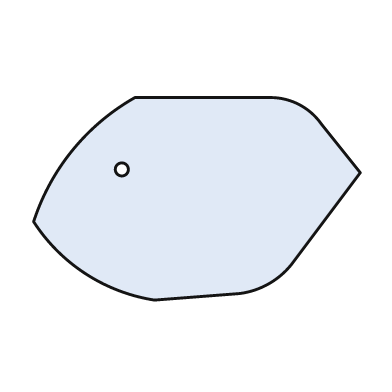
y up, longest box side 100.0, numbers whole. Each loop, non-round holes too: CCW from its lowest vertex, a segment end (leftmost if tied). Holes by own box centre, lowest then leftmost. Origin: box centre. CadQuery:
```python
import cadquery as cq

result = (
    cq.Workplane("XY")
    .moveTo(-13.0, -31.0)
    .lineTo(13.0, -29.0)
    .threePointArc((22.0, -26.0), (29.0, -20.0))
    .lineTo(50.0, 8.0)
    .lineTo(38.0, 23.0)
    .threePointArc((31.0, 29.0), (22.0, 31.0))
    .lineTo(-19.0, 31.0)
    .threePointArc((-38.0, 15.0), (-50.0, -7.0))
    .threePointArc((-34.0, -23.0), (-13.0, -31.0))
    .close()
    .moveTo(-23.0, 9.0)
    .circle(2.0)
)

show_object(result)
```